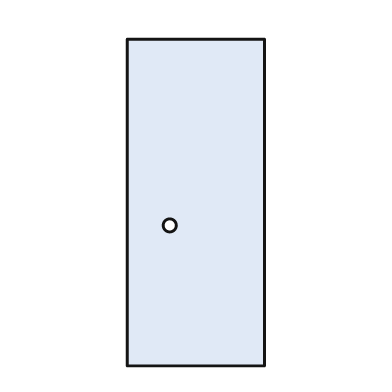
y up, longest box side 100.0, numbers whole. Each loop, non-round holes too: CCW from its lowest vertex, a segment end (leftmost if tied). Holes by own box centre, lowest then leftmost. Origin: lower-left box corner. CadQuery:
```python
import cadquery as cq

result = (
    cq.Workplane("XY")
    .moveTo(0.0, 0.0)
    .lineTo(42.0, 0.0)
    .lineTo(42.0, 100.0)
    .lineTo(0.0, 100.0)
    .close()
    .moveTo(13.0, 43.0)
    .circle(2.0)
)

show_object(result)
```